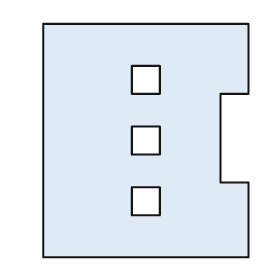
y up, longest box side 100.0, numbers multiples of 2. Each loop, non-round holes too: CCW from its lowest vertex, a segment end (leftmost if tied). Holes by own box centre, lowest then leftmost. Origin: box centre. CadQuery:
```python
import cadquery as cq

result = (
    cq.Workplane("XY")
    .moveTo(-44.0, -50.0)
    .lineTo(44.0, -50.0)
    .lineTo(44.0, -18.0)
    .lineTo(32.0, -18.0)
    .lineTo(32.0, 20.0)
    .lineTo(44.0, 20.0)
    .lineTo(44.0, 50.0)
    .lineTo(-44.0, 50.0)
    .close()
    .moveTo(-6.0, -32.0)
    .lineTo(6.0, -32.0)
    .lineTo(6.0, -20.0)
    .lineTo(-6.0, -20.0)
    .close()
    .moveTo(-6.0, -6.0)
    .lineTo(6.0, -6.0)
    .lineTo(6.0, 6.0)
    .lineTo(-6.0, 6.0)
    .close()
    .moveTo(-6.0, 20.0)
    .lineTo(6.0, 20.0)
    .lineTo(6.0, 32.0)
    .lineTo(-6.0, 32.0)
    .close()
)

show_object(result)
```